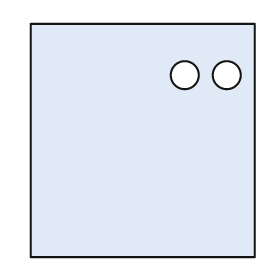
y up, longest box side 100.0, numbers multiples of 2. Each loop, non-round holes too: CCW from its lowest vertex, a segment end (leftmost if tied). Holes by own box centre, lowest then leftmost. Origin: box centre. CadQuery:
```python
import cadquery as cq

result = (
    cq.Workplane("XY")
    .moveTo(-48.0, -50.0)
    .lineTo(48.0, -50.0)
    .lineTo(48.0, 50.0)
    .lineTo(-48.0, 50.0)
    .close()
    .moveTo(18.0, 28.0)
    .circle(6.0)
    .moveTo(36.0, 28.0)
    .circle(6.0)
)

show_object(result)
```